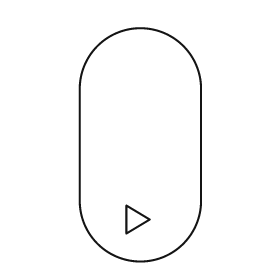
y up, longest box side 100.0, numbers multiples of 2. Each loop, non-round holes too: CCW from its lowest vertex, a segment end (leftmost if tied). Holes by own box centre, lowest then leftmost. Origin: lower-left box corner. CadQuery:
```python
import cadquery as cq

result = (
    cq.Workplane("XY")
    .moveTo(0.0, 26.0)
    .threePointArc((26.0, 0.0), (52.0, 26.0))
    .lineTo(52.0, 74.0)
    .threePointArc((26.0, 100.0), (0.0, 74.0))
    .close()
    .moveTo(20.0, 12.0)
    .lineTo(30.0, 18.0)
    .lineTo(20.0, 24.0)
    .close()
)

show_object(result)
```